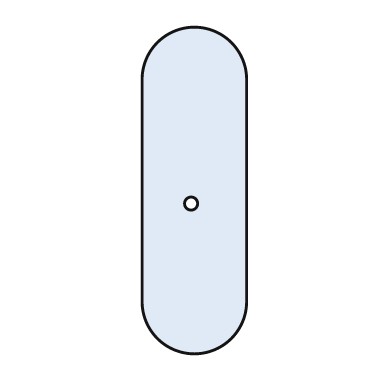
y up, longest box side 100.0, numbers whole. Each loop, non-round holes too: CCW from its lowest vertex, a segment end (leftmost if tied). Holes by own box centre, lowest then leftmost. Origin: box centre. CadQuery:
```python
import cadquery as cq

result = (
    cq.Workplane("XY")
    .moveTo(-16.0, -34.0)
    .threePointArc((0.0, -50.0), (16.0, -34.0))
    .lineTo(16.0, 34.0)
    .threePointArc((0.0, 50.0), (-16.0, 34.0))
    .close()
    .moveTo(-1.0, -4.0)
    .circle(2.0)
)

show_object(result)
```